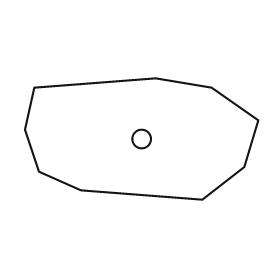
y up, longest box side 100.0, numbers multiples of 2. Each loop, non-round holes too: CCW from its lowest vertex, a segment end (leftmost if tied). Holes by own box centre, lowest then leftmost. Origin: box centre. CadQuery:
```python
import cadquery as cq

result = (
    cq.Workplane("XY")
    .moveTo(26.0, -26.0)
    .lineTo(44.0, -12.0)
    .lineTo(50.0, 8.0)
    .lineTo(30.0, 22.0)
    .lineTo(6.0, 26.0)
    .lineTo(-46.0, 22.0)
    .lineTo(-50.0, 4.0)
    .lineTo(-44.0, -14.0)
    .lineTo(-26.0, -22.0)
    .close()
    .moveTo(0.0, 0.0)
    .circle(4.0)
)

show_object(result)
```